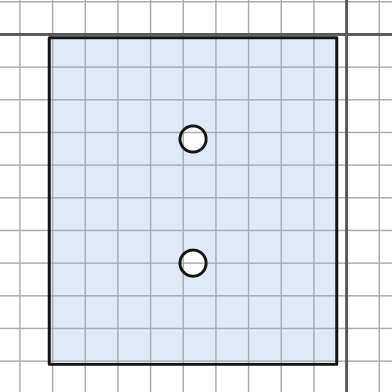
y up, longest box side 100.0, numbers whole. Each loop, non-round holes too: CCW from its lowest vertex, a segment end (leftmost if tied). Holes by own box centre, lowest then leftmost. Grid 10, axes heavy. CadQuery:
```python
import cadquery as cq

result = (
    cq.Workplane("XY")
    .moveTo(-91.0, -101.0)
    .lineTo(-3.0, -101.0)
    .lineTo(-3.0, -1.0)
    .lineTo(-91.0, -1.0)
    .close()
    .moveTo(-47.0, -70.0)
    .circle(4.0)
    .moveTo(-47.0, -32.0)
    .circle(4.0)
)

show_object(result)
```